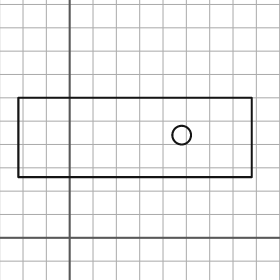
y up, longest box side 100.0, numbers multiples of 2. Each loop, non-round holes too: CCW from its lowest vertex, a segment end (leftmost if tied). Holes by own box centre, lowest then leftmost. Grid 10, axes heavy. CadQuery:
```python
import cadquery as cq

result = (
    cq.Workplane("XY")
    .moveTo(-22.0, 26.0)
    .lineTo(78.0, 26.0)
    .lineTo(78.0, 60.0)
    .lineTo(-22.0, 60.0)
    .close()
    .moveTo(48.0, 44.0)
    .circle(4.0)
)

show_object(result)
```